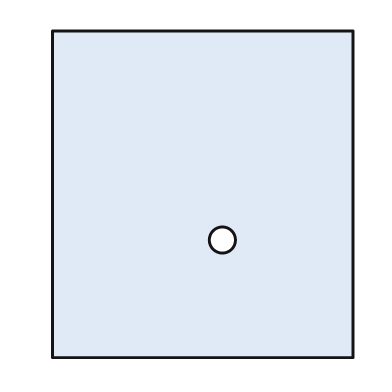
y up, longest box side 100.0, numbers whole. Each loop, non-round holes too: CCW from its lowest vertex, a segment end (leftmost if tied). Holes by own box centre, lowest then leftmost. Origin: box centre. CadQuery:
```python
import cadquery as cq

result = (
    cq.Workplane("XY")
    .moveTo(-46.0, -50.0)
    .lineTo(46.0, -50.0)
    .lineTo(46.0, 50.0)
    .lineTo(-46.0, 50.0)
    .close()
    .moveTo(6.0, -14.0)
    .circle(4.0)
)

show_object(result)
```